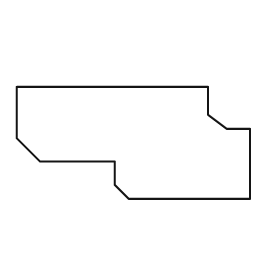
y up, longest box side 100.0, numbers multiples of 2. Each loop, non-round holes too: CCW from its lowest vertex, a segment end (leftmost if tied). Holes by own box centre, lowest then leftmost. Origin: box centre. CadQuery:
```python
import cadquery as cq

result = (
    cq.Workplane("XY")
    .moveTo(-2.0, -24.0)
    .lineTo(50.0, -24.0)
    .lineTo(50.0, 6.0)
    .lineTo(40.0, 6.0)
    .lineTo(32.0, 12.0)
    .lineTo(32.0, 24.0)
    .lineTo(-50.0, 24.0)
    .lineTo(-50.0, 2.0)
    .lineTo(-40.0, -8.0)
    .lineTo(-8.0, -8.0)
    .lineTo(-8.0, -18.0)
    .close()
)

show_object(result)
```